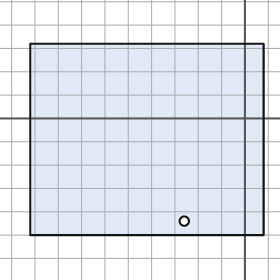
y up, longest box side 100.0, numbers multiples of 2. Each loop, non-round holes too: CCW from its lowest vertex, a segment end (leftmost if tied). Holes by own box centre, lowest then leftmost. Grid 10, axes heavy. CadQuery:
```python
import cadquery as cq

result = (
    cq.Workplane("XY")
    .moveTo(-92.0, -50.0)
    .lineTo(8.0, -50.0)
    .lineTo(8.0, 32.0)
    .lineTo(-92.0, 32.0)
    .close()
    .moveTo(-26.0, -44.0)
    .circle(2.0)
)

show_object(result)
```